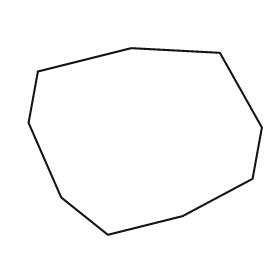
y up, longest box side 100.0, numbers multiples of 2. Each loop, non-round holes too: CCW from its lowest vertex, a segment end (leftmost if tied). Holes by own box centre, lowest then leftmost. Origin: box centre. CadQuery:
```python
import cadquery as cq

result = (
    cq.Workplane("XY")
    .moveTo(-16.0, -40.0)
    .lineTo(16.0, -32.0)
    .lineTo(46.0, -16.0)
    .lineTo(50.0, 6.0)
    .lineTo(32.0, 38.0)
    .lineTo(-6.0, 40.0)
    .lineTo(-46.0, 30.0)
    .lineTo(-50.0, 8.0)
    .lineTo(-36.0, -24.0)
    .close()
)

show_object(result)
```